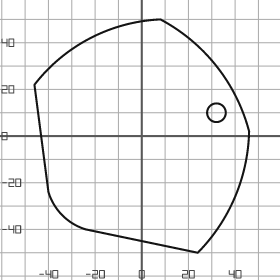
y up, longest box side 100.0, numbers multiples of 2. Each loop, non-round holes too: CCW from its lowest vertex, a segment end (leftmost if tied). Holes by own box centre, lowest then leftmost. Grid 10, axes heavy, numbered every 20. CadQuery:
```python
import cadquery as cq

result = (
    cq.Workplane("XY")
    .moveTo(24.0, -50.0)
    .threePointArc((40.0, -26.0), (46.0, 2.0))
    .threePointArc((32.0, 30.0), (8.0, 50.0))
    .threePointArc((-22.0, 42.0), (-46.0, 22.0))
    .lineTo(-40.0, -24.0)
    .threePointArc((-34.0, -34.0), (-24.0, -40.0))
    .close()
    .moveTo(32.0, 10.0)
    .circle(4.0)
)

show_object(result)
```